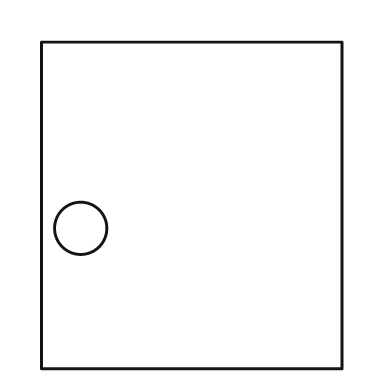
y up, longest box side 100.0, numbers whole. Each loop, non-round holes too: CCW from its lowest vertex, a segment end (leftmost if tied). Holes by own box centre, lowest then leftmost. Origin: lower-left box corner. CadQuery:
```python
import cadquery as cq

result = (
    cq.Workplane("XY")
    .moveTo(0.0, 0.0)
    .lineTo(92.0, 0.0)
    .lineTo(92.0, 100.0)
    .lineTo(0.0, 100.0)
    .close()
    .moveTo(12.0, 43.0)
    .circle(8.0)
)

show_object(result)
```